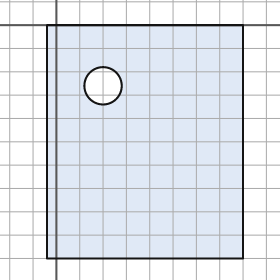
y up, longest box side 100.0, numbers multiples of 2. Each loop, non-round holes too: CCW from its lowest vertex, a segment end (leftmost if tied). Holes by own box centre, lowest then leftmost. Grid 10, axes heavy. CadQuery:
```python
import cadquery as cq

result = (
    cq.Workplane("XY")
    .moveTo(-4.0, -100.0)
    .lineTo(80.0, -100.0)
    .lineTo(80.0, 0.0)
    .lineTo(-4.0, 0.0)
    .close()
    .moveTo(20.0, -26.0)
    .circle(8.0)
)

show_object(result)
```